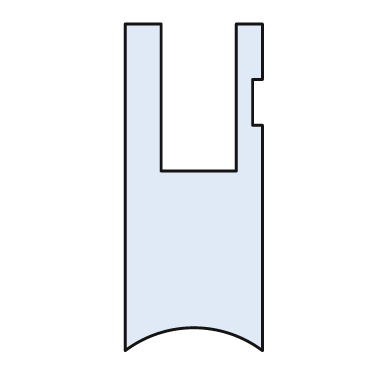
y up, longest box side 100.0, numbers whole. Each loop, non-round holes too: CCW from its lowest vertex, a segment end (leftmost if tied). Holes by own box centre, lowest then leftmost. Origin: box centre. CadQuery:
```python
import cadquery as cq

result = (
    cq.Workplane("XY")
    .moveTo(-21.0, -50.0)
    .threePointArc((0.0, -43.0), (21.0, -50.0))
    .lineTo(21.0, 19.0)
    .lineTo(18.0, 19.0)
    .lineTo(18.0, 33.0)
    .lineTo(21.0, 33.0)
    .lineTo(21.0, 50.0)
    .lineTo(13.0, 50.0)
    .lineTo(13.0, 5.0)
    .lineTo(-10.0, 5.0)
    .lineTo(-10.0, 50.0)
    .lineTo(-21.0, 50.0)
    .close()
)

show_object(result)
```